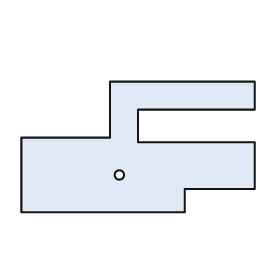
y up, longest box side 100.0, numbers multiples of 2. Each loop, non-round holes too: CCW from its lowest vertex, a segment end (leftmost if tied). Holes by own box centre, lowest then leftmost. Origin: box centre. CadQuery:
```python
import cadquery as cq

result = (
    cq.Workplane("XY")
    .moveTo(-50.0, -28.0)
    .lineTo(20.0, -28.0)
    .lineTo(20.0, -18.0)
    .lineTo(50.0, -18.0)
    .lineTo(50.0, 2.0)
    .lineTo(0.0, 2.0)
    .lineTo(0.0, 16.0)
    .lineTo(50.0, 16.0)
    .lineTo(50.0, 28.0)
    .lineTo(-12.0, 28.0)
    .lineTo(-12.0, 4.0)
    .lineTo(-50.0, 4.0)
    .close()
    .moveTo(-8.0, -12.0)
    .circle(2.0)
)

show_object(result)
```